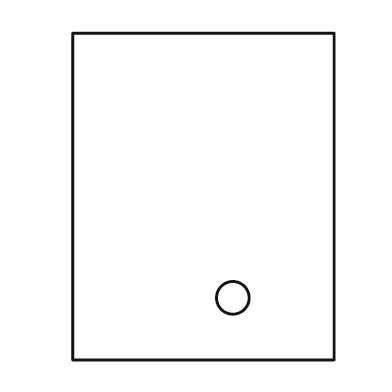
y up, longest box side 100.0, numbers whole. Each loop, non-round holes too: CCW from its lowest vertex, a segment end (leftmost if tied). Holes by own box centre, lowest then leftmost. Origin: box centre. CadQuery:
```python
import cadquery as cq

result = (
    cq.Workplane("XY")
    .moveTo(-40.0, -50.0)
    .lineTo(40.0, -50.0)
    .lineTo(40.0, 50.0)
    .lineTo(-40.0, 50.0)
    .close()
    .moveTo(9.0, -31.0)
    .circle(5.0)
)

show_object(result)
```